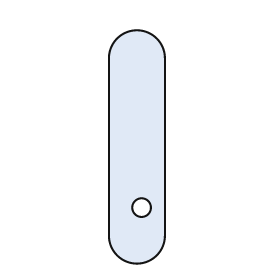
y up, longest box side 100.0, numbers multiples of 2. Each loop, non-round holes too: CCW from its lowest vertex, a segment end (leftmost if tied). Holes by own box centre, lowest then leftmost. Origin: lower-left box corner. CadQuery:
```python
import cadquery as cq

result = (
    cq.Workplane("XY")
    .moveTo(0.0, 12.0)
    .threePointArc((12.0, 0.0), (24.0, 12.0))
    .lineTo(24.0, 88.0)
    .threePointArc((12.0, 100.0), (0.0, 88.0))
    .close()
    .moveTo(14.0, 24.0)
    .circle(4.0)
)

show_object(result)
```